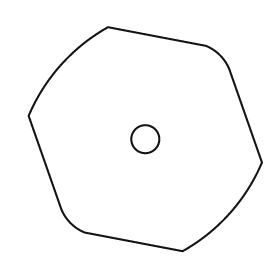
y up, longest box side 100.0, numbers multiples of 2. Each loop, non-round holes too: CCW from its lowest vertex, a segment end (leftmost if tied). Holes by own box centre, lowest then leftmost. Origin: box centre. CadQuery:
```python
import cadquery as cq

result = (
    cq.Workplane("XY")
    .moveTo(16.0, -48.0)
    .threePointArc((36.0, -32.0), (50.0, -10.0))
    .lineTo(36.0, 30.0)
    .threePointArc((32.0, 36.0), (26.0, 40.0))
    .lineTo(-16.0, 48.0)
    .threePointArc((-36.0, 32.0), (-50.0, 10.0))
    .lineTo(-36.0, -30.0)
    .threePointArc((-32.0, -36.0), (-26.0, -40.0))
    .close()
    .moveTo(0.0, 0.0)
    .circle(6.0)
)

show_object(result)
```